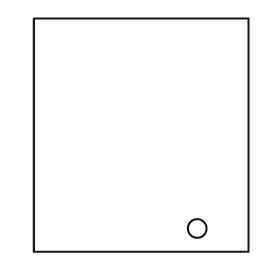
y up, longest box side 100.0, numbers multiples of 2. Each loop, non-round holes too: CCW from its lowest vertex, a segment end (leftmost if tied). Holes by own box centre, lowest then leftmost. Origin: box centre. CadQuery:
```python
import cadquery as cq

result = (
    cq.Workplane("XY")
    .moveTo(-46.0, -50.0)
    .lineTo(46.0, -50.0)
    .lineTo(46.0, 50.0)
    .lineTo(-46.0, 50.0)
    .close()
    .moveTo(24.0, -40.0)
    .circle(4.0)
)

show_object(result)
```